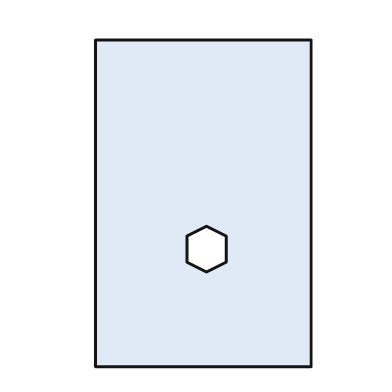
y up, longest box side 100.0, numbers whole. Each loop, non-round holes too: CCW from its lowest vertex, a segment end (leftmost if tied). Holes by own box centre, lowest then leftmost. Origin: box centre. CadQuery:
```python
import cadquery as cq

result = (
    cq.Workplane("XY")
    .moveTo(-33.0, -50.0)
    .lineTo(33.0, -50.0)
    .lineTo(33.0, 50.0)
    .lineTo(-33.0, 50.0)
    .close()
    .moveTo(1.0, -21.0)
    .lineTo(7.0, -18.0)
    .lineTo(7.0, -10.0)
    .lineTo(1.0, -7.0)
    .lineTo(-5.0, -10.0)
    .lineTo(-5.0, -18.0)
    .close()
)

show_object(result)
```